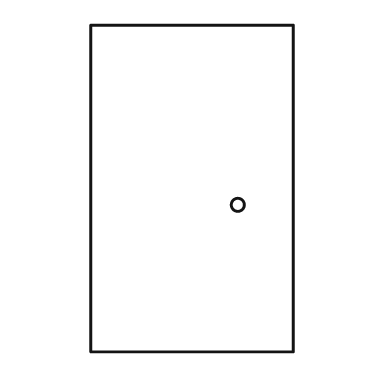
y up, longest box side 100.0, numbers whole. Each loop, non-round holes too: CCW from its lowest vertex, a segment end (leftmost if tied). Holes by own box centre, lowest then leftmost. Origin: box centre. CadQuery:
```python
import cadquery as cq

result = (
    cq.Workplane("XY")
    .moveTo(-31.0, -50.0)
    .lineTo(31.0, -50.0)
    .lineTo(31.0, 50.0)
    .lineTo(-31.0, 50.0)
    .close()
    .moveTo(14.0, -5.0)
    .circle(2.0)
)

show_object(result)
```